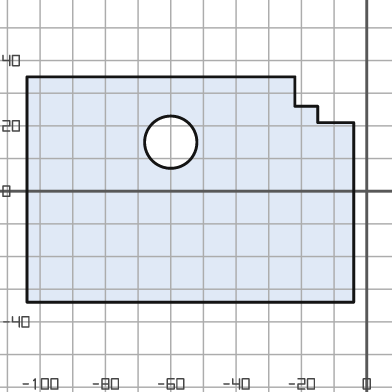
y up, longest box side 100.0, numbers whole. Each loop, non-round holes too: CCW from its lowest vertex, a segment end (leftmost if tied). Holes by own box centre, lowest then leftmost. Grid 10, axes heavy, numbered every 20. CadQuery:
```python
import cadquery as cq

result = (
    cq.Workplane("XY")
    .moveTo(-104.0, -34.0)
    .lineTo(-4.0, -34.0)
    .lineTo(-4.0, 21.0)
    .lineTo(-15.0, 21.0)
    .lineTo(-15.0, 26.0)
    .lineTo(-22.0, 26.0)
    .lineTo(-22.0, 35.0)
    .lineTo(-104.0, 35.0)
    .close()
    .moveTo(-60.0, 15.0)
    .circle(8.0)
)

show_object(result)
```